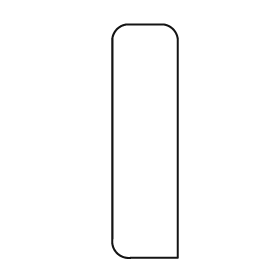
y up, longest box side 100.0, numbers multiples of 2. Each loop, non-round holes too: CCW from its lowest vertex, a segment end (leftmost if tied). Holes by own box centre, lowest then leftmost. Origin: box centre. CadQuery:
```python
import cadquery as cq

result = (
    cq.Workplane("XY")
    .moveTo(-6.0, -50.0)
    .lineTo(14.0, -50.0)
    .lineTo(14.0, 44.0)
    .threePointArc((12.0, 48.0), (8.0, 50.0))
    .lineTo(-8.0, 50.0)
    .threePointArc((-12.0, 48.0), (-14.0, 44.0))
    .lineTo(-14.0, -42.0)
    .threePointArc((-12.0, -48.0), (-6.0, -50.0))
    .close()
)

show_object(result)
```